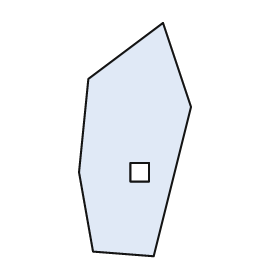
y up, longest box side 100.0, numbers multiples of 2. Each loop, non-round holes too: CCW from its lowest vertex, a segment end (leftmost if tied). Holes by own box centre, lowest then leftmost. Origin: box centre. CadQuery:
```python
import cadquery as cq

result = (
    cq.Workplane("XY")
    .moveTo(8.0, -50.0)
    .lineTo(24.0, 14.0)
    .lineTo(12.0, 50.0)
    .lineTo(-20.0, 26.0)
    .lineTo(-24.0, -14.0)
    .lineTo(-18.0, -48.0)
    .close()
    .moveTo(-2.0, -18.0)
    .lineTo(6.0, -18.0)
    .lineTo(6.0, -10.0)
    .lineTo(-2.0, -10.0)
    .close()
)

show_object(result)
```